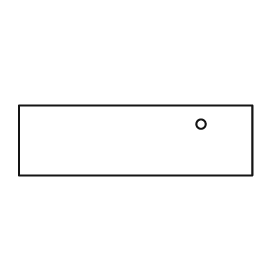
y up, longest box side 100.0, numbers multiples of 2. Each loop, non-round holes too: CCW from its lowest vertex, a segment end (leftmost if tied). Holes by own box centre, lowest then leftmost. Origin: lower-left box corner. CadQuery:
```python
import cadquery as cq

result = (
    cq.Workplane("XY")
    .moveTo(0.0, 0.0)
    .lineTo(100.0, 0.0)
    .lineTo(100.0, 30.0)
    .lineTo(0.0, 30.0)
    .close()
    .moveTo(78.0, 22.0)
    .circle(2.0)
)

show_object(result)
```